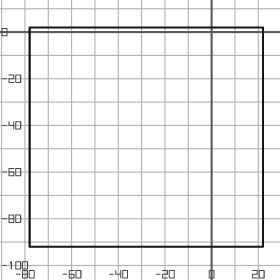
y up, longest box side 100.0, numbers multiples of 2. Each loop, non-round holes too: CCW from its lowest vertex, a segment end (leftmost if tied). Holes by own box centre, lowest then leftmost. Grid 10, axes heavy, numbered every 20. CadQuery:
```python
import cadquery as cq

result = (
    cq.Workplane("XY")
    .moveTo(-78.0, -92.0)
    .lineTo(22.0, -92.0)
    .lineTo(22.0, 2.0)
    .lineTo(-78.0, 2.0)
    .close()
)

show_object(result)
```